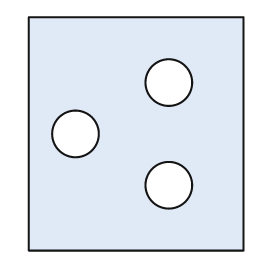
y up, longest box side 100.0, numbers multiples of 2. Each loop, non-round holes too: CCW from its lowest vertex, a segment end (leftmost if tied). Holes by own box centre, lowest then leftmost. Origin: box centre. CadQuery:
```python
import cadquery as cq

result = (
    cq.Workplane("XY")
    .moveTo(-46.0, -50.0)
    .lineTo(46.0, -50.0)
    .lineTo(46.0, 50.0)
    .lineTo(-46.0, 50.0)
    .close()
    .moveTo(14.0, -22.0)
    .circle(10.0)
    .moveTo(-26.0, 0.0)
    .circle(10.0)
    .moveTo(14.0, 22.0)
    .circle(10.0)
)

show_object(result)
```